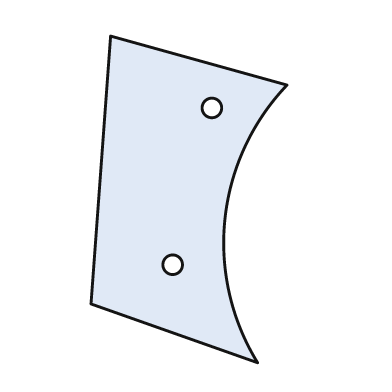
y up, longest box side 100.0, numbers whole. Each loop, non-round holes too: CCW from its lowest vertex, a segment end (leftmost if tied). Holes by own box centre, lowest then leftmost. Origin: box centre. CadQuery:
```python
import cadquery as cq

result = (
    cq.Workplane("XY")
    .moveTo(21.0, -50.0)
    .threePointArc((11.0, -6.0), (30.0, 35.0))
    .lineTo(-24.0, 50.0)
    .lineTo(-30.0, -32.0)
    .close()
    .moveTo(-5.0, -20.0)
    .circle(3.0)
    .moveTo(7.0, 28.0)
    .circle(3.0)
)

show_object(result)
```